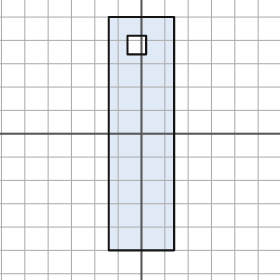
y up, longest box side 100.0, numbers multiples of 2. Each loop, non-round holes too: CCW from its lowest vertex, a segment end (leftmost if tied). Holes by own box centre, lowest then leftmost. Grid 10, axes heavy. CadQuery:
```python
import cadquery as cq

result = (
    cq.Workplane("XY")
    .moveTo(-14.0, -50.0)
    .lineTo(14.0, -50.0)
    .lineTo(14.0, 50.0)
    .lineTo(-14.0, 50.0)
    .close()
    .moveTo(-6.0, 34.0)
    .lineTo(2.0, 34.0)
    .lineTo(2.0, 42.0)
    .lineTo(-6.0, 42.0)
    .close()
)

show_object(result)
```